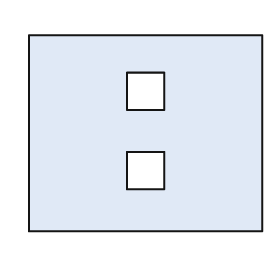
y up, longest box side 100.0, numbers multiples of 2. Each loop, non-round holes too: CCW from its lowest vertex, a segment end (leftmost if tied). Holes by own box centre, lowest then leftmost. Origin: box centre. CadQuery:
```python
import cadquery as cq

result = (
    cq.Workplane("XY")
    .moveTo(-50.0, -42.0)
    .lineTo(50.0, -42.0)
    .lineTo(50.0, 42.0)
    .lineTo(-50.0, 42.0)
    .close()
    .moveTo(-8.0, -24.0)
    .lineTo(8.0, -24.0)
    .lineTo(8.0, -8.0)
    .lineTo(-8.0, -8.0)
    .close()
    .moveTo(-8.0, 10.0)
    .lineTo(8.0, 10.0)
    .lineTo(8.0, 26.0)
    .lineTo(-8.0, 26.0)
    .close()
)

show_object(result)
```